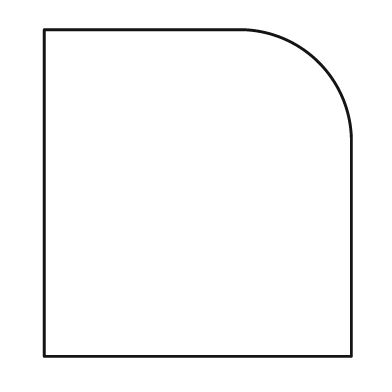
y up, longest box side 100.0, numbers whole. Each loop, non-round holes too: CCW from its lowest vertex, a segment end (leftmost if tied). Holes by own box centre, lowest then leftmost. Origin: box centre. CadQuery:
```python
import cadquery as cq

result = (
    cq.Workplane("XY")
    .moveTo(-47.0, -50.0)
    .lineTo(47.0, -50.0)
    .lineTo(47.0, 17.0)
    .threePointArc((37.0, 40.0), (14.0, 50.0))
    .lineTo(-47.0, 50.0)
    .close()
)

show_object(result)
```